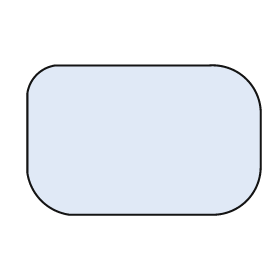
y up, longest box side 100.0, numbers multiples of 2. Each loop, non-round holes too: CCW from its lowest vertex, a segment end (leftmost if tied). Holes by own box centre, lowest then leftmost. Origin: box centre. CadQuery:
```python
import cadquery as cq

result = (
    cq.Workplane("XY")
    .moveTo(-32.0, -32.0)
    .lineTo(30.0, -32.0)
    .threePointArc((44.0, -26.0), (50.0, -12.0))
    .lineTo(50.0, 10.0)
    .threePointArc((44.0, 26.0), (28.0, 32.0))
    .lineTo(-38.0, 32.0)
    .threePointArc((-46.0, 28.0), (-50.0, 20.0))
    .lineTo(-50.0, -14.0)
    .threePointArc((-44.0, -26.0), (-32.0, -32.0))
    .close()
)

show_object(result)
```